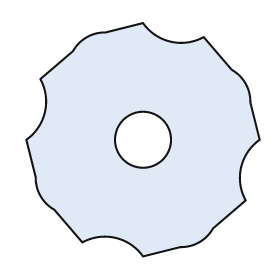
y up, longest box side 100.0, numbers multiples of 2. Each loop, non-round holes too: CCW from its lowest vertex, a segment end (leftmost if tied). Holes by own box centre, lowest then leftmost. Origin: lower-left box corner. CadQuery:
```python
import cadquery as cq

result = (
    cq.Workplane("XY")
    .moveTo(50.0, 0.0)
    .lineTo(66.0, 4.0)
    .threePointArc((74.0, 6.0), (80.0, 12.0))
    .lineTo(94.0, 24.0)
    .threePointArc((92.0, 38.0), (100.0, 50.0))
    .lineTo(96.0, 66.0)
    .threePointArc((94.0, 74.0), (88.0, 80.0))
    .lineTo(76.0, 94.0)
    .threePointArc((62.0, 92.0), (50.0, 100.0))
    .lineTo(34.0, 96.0)
    .threePointArc((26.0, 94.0), (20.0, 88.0))
    .lineTo(6.0, 76.0)
    .threePointArc((8.0, 62.0), (0.0, 50.0))
    .lineTo(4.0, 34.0)
    .threePointArc((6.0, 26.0), (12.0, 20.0))
    .lineTo(24.0, 6.0)
    .threePointArc((38.0, 8.0), (50.0, 0.0))
    .close()
    .moveTo(50.0, 50.0)
    .circle(12.0)
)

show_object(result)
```